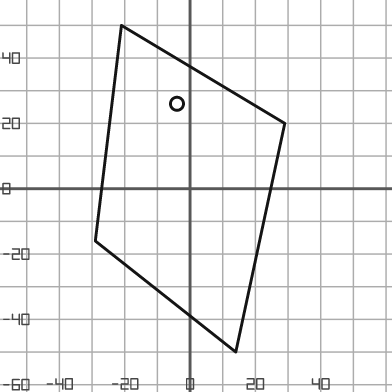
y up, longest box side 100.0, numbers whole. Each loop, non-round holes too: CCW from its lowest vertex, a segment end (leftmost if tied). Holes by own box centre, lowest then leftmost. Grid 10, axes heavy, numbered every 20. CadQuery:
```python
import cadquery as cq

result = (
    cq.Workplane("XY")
    .moveTo(14.0, -50.0)
    .lineTo(29.0, 20.0)
    .lineTo(-21.0, 50.0)
    .lineTo(-29.0, -16.0)
    .close()
    .moveTo(-4.0, 26.0)
    .circle(2.0)
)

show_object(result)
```